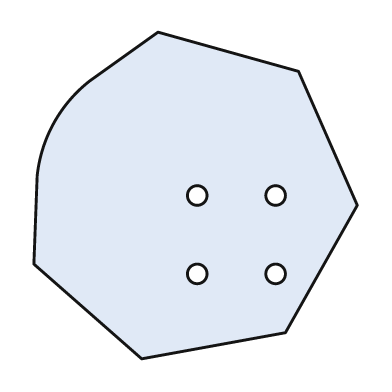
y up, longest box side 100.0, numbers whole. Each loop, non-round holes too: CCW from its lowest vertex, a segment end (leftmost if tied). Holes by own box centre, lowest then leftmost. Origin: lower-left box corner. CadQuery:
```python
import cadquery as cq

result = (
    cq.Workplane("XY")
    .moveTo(33.0, 0.0)
    .lineTo(77.0, 8.0)
    .lineTo(99.0, 47.0)
    .lineTo(81.0, 88.0)
    .lineTo(38.0, 100.0)
    .lineTo(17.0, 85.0)
    .threePointArc((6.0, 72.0), (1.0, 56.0))
    .lineTo(0.0, 29.0)
    .close()
    .moveTo(50.0, 26.0)
    .circle(3.0)
    .moveTo(74.0, 26.0)
    .circle(3.0)
    .moveTo(50.0, 50.0)
    .circle(3.0)
    .moveTo(74.0, 50.0)
    .circle(3.0)
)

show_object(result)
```